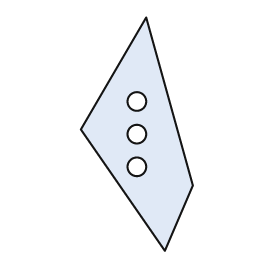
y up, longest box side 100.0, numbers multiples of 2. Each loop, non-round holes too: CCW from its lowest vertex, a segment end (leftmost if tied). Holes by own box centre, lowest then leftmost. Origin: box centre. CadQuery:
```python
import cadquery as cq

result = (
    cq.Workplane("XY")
    .moveTo(12.0, -50.0)
    .lineTo(24.0, -22.0)
    .lineTo(4.0, 50.0)
    .lineTo(-24.0, 2.0)
    .close()
    .moveTo(0.0, -14.0)
    .circle(4.0)
    .moveTo(0.0, 0.0)
    .circle(4.0)
    .moveTo(0.0, 14.0)
    .circle(4.0)
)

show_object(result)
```